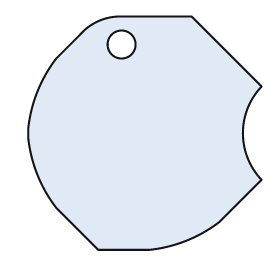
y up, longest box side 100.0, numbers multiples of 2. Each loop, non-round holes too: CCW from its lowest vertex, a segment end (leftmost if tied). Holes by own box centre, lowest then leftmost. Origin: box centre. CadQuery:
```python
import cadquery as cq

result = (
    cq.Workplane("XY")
    .moveTo(-20.0, -50.0)
    .lineTo(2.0, -50.0)
    .threePointArc((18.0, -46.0), (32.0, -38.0))
    .lineTo(50.0, -20.0)
    .threePointArc((42.0, 0.0), (50.0, 20.0))
    .lineTo(20.0, 50.0)
    .lineTo(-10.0, 50.0)
    .threePointArc((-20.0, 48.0), (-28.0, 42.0))
    .lineTo(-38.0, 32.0)
    .threePointArc((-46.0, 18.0), (-50.0, 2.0))
    .lineTo(-50.0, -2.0)
    .threePointArc((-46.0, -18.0), (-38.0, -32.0))
    .close()
    .moveTo(-10.0, 38.0)
    .circle(6.0)
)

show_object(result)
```